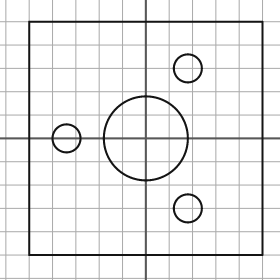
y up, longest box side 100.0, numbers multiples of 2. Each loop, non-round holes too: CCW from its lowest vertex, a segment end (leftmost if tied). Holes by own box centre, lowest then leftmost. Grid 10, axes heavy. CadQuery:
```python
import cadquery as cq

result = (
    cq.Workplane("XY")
    .moveTo(-50.0, -50.0)
    .lineTo(50.0, -50.0)
    .lineTo(50.0, 50.0)
    .lineTo(-50.0, 50.0)
    .close()
    .moveTo(18.0, -30.0)
    .circle(6.0)
    .moveTo(-34.0, 0.0)
    .circle(6.0)
    .moveTo(0.0, 0.0)
    .circle(18.0)
    .moveTo(18.0, 30.0)
    .circle(6.0)
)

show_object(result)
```